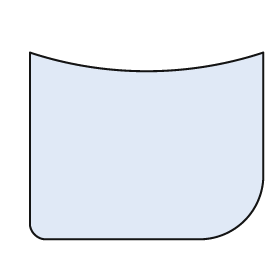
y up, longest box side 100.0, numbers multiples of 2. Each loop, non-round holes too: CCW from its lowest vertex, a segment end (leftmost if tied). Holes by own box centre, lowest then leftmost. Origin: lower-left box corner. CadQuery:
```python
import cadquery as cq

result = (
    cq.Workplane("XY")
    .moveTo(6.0, 0.0)
    .lineTo(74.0, 0.0)
    .threePointArc((92.0, 8.0), (100.0, 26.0))
    .lineTo(100.0, 80.0)
    .threePointArc((50.0, 72.0), (0.0, 80.0))
    .lineTo(0.0, 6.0)
    .threePointArc((2.0, 2.0), (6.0, 0.0))
    .close()
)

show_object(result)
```